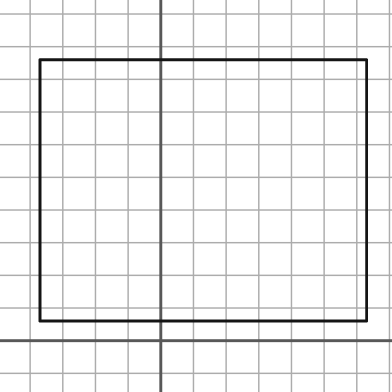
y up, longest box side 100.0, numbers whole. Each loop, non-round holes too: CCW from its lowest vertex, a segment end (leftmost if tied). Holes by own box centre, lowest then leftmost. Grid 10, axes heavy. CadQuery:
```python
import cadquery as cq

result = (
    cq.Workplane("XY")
    .moveTo(-37.0, 6.0)
    .lineTo(63.0, 6.0)
    .lineTo(63.0, 86.0)
    .lineTo(-37.0, 86.0)
    .close()
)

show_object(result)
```